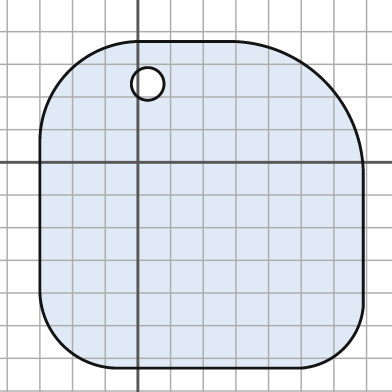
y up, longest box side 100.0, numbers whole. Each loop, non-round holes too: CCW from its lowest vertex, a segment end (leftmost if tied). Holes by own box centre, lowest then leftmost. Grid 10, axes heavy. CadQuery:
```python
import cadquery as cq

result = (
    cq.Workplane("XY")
    .moveTo(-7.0, -63.0)
    .lineTo(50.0, -63.0)
    .threePointArc((63.0, -57.0), (69.0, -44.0))
    .lineTo(69.0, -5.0)
    .threePointArc((57.0, 25.0), (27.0, 37.0))
    .lineTo(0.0, 37.0)
    .threePointArc((-21.0, 28.0), (-30.0, 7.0))
    .lineTo(-30.0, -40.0)
    .threePointArc((-23.0, -56.0), (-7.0, -63.0))
    .close()
    .moveTo(3.0, 24.0)
    .circle(5.0)
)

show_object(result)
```